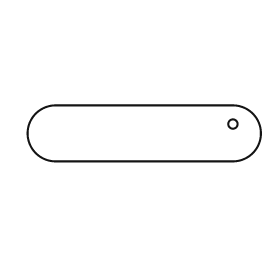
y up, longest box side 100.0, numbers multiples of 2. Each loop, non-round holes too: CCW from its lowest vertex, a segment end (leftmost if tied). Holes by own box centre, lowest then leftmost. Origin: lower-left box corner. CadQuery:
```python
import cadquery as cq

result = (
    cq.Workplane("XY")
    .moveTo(12.0, 0.0)
    .lineTo(88.0, 0.0)
    .threePointArc((100.0, 12.0), (88.0, 24.0))
    .lineTo(12.0, 24.0)
    .threePointArc((0.0, 12.0), (12.0, 0.0))
    .close()
    .moveTo(88.0, 16.0)
    .circle(2.0)
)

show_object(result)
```